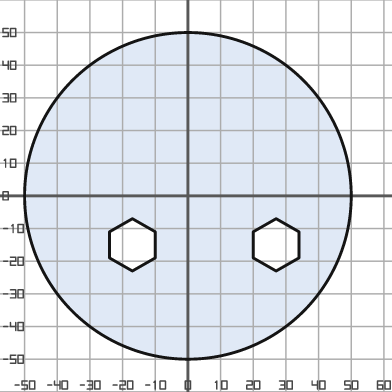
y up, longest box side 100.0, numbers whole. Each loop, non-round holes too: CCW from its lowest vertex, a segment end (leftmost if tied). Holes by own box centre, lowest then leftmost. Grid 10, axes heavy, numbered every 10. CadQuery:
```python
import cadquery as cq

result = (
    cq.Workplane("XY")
    .moveTo(0.0, 0.0)
    .circle(50.0)
    .moveTo(-17.0, -23.0)
    .lineTo(-10.0, -19.0)
    .lineTo(-10.0, -11.0)
    .lineTo(-17.0, -7.0)
    .lineTo(-24.0, -11.0)
    .lineTo(-24.0, -19.0)
    .close()
    .moveTo(27.0, -23.0)
    .lineTo(34.0, -19.0)
    .lineTo(34.0, -11.0)
    .lineTo(27.0, -7.0)
    .lineTo(20.0, -11.0)
    .lineTo(20.0, -19.0)
    .close()
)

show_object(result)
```